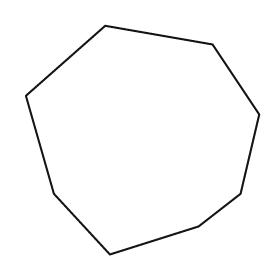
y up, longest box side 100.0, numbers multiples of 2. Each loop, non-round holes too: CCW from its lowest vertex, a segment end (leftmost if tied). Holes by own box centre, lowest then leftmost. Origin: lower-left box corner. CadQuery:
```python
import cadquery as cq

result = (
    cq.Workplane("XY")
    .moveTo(36.0, 0.0)
    .lineTo(74.0, 12.0)
    .lineTo(92.0, 26.0)
    .lineTo(100.0, 60.0)
    .lineTo(80.0, 90.0)
    .lineTo(34.0, 98.0)
    .lineTo(0.0, 68.0)
    .lineTo(12.0, 26.0)
    .close()
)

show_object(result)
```